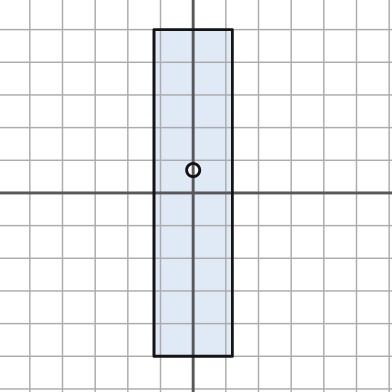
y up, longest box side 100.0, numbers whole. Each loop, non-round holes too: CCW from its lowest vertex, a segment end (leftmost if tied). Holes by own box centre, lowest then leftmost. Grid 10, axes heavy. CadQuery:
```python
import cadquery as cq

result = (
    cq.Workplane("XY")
    .moveTo(-12.0, -50.0)
    .lineTo(12.0, -50.0)
    .lineTo(12.0, 50.0)
    .lineTo(-12.0, 50.0)
    .close()
    .moveTo(0.0, 7.0)
    .circle(2.0)
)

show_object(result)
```